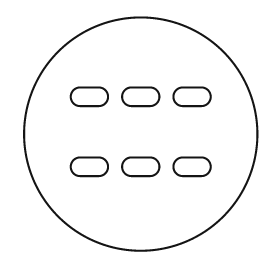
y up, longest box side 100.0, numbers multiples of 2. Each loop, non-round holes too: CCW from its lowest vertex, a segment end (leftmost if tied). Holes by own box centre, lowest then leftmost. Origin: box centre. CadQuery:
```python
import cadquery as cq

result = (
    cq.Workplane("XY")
    .moveTo(0.0, 0.0)
    .circle(50.0)
    .moveTo(-26.0, -18.0)
    .lineTo(-18.0, -18.0)
    .threePointArc((-14.0, -14.0), (-18.0, -10.0))
    .lineTo(-26.0, -10.0)
    .threePointArc((-30.0, -14.0), (-26.0, -18.0))
    .close()
    .moveTo(-4.0, -18.0)
    .lineTo(4.0, -18.0)
    .threePointArc((8.0, -14.0), (4.0, -10.0))
    .lineTo(-4.0, -10.0)
    .threePointArc((-8.0, -14.0), (-4.0, -18.0))
    .close()
    .moveTo(18.0, -18.0)
    .lineTo(26.0, -18.0)
    .threePointArc((30.0, -14.0), (26.0, -10.0))
    .lineTo(18.0, -10.0)
    .threePointArc((14.0, -14.0), (18.0, -18.0))
    .close()
    .moveTo(-26.0, 12.0)
    .lineTo(-18.0, 12.0)
    .threePointArc((-14.0, 16.0), (-18.0, 20.0))
    .lineTo(-26.0, 20.0)
    .threePointArc((-30.0, 16.0), (-26.0, 12.0))
    .close()
    .moveTo(-4.0, 12.0)
    .lineTo(4.0, 12.0)
    .threePointArc((8.0, 16.0), (4.0, 20.0))
    .lineTo(-4.0, 20.0)
    .threePointArc((-8.0, 16.0), (-4.0, 12.0))
    .close()
    .moveTo(18.0, 12.0)
    .lineTo(26.0, 12.0)
    .threePointArc((30.0, 16.0), (26.0, 20.0))
    .lineTo(18.0, 20.0)
    .threePointArc((14.0, 16.0), (18.0, 12.0))
    .close()
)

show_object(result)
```